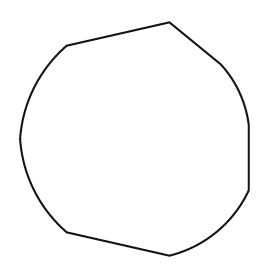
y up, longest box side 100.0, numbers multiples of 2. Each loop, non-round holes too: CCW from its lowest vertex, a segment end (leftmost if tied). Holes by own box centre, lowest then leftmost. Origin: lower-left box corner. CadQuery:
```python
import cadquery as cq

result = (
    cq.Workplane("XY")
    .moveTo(64.0, 0.0)
    .threePointArc((84.0, 10.0), (98.0, 28.0))
    .lineTo(98.0, 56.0)
    .threePointArc((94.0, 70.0), (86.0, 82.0))
    .lineTo(64.0, 100.0)
    .lineTo(20.0, 90.0)
    .threePointArc((6.0, 72.0), (0.0, 50.0))
    .threePointArc((6.0, 28.0), (20.0, 10.0))
    .close()
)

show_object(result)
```